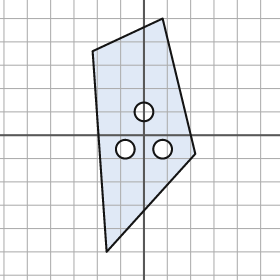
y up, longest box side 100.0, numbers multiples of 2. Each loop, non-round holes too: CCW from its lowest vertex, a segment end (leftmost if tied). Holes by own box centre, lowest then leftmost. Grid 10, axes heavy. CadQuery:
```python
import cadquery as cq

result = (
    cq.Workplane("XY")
    .moveTo(-16.0, -50.0)
    .lineTo(22.0, -8.0)
    .lineTo(8.0, 50.0)
    .lineTo(-22.0, 36.0)
    .close()
    .moveTo(-8.0, -6.0)
    .circle(4.0)
    .moveTo(8.0, -6.0)
    .circle(4.0)
    .moveTo(0.0, 10.0)
    .circle(4.0)
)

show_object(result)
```